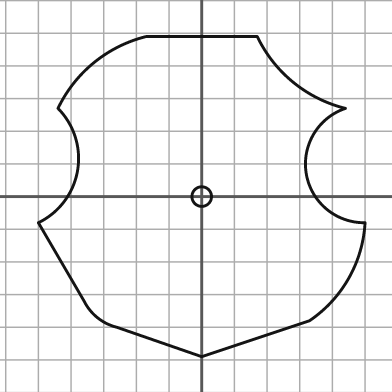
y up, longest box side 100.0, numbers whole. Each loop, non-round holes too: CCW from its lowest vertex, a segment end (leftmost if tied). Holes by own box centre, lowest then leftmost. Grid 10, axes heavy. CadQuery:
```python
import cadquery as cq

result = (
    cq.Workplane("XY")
    .moveTo(0.0, -49.0)
    .lineTo(33.0, -38.0)
    .threePointArc((45.0, -25.0), (50.0, -8.0))
    .threePointArc((32.0, 7.0), (44.0, 27.0))
    .threePointArc((28.0, 35.0), (17.0, 49.0))
    .lineTo(-17.0, 49.0)
    .threePointArc((-33.0, 41.0), (-44.0, 27.0))
    .threePointArc((-38.0, 8.0), (-50.0, -8.0))
    .lineTo(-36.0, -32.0)
    .threePointArc((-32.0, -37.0), (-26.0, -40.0))
    .close()
    .moveTo(0.0, 0.0)
    .circle(3.0)
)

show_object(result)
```